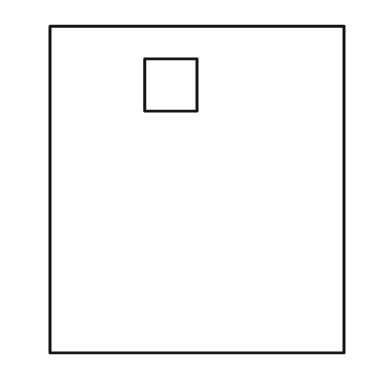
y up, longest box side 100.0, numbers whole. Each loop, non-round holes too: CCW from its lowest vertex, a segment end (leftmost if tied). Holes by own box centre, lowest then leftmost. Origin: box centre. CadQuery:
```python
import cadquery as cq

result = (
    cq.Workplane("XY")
    .moveTo(-45.0, -50.0)
    .lineTo(45.0, -50.0)
    .lineTo(45.0, 50.0)
    .lineTo(-45.0, 50.0)
    .close()
    .moveTo(-16.0, 24.0)
    .lineTo(0.0, 24.0)
    .lineTo(0.0, 40.0)
    .lineTo(-16.0, 40.0)
    .close()
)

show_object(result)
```